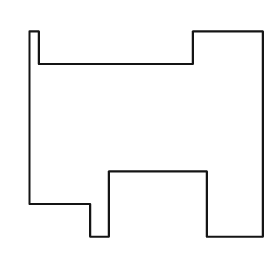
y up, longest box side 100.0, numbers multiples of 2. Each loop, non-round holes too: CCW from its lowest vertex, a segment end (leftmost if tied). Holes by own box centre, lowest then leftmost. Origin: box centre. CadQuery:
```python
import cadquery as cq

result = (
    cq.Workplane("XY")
    .moveTo(-24.0, -44.0)
    .lineTo(-16.0, -44.0)
    .lineTo(-16.0, -16.0)
    .lineTo(26.0, -16.0)
    .lineTo(26.0, -44.0)
    .lineTo(50.0, -44.0)
    .lineTo(50.0, 44.0)
    .lineTo(20.0, 44.0)
    .lineTo(20.0, 30.0)
    .lineTo(-46.0, 30.0)
    .lineTo(-46.0, 44.0)
    .lineTo(-50.0, 44.0)
    .lineTo(-50.0, -30.0)
    .lineTo(-24.0, -30.0)
    .close()
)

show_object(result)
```